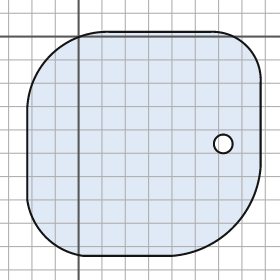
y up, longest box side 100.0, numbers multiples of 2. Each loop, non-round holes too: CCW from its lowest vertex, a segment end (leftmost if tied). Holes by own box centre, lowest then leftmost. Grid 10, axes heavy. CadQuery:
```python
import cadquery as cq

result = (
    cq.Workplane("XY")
    .moveTo(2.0, -94.0)
    .lineTo(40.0, -94.0)
    .threePointArc((66.0, -82.0), (78.0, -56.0))
    .lineTo(78.0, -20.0)
    .threePointArc((72.0, -4.0), (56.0, 2.0))
    .lineTo(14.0, 2.0)
    .threePointArc((-12.0, -8.0), (-22.0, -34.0))
    .lineTo(-22.0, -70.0)
    .threePointArc((-14.0, -86.0), (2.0, -94.0))
    .close()
    .moveTo(62.0, -46.0)
    .circle(4.0)
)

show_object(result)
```